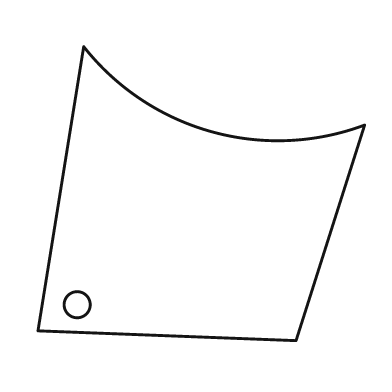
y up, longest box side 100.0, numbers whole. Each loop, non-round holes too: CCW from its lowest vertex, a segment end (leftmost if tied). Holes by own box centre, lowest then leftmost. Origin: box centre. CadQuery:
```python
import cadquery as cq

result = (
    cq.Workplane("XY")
    .moveTo(29.0, -45.0)
    .lineTo(50.0, 21.0)
    .threePointArc((3.0, 19.0), (-36.0, 45.0))
    .lineTo(-50.0, -42.0)
    .close()
    .moveTo(-38.0, -34.0)
    .circle(4.0)
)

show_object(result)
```